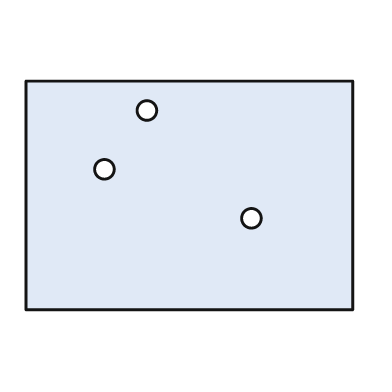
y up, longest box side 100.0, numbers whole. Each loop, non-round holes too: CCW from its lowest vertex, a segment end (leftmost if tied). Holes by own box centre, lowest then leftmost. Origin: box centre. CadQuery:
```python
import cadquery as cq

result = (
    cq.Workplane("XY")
    .moveTo(-50.0, -35.0)
    .lineTo(50.0, -35.0)
    .lineTo(50.0, 35.0)
    .lineTo(-50.0, 35.0)
    .close()
    .moveTo(19.0, -7.0)
    .circle(3.0)
    .moveTo(-26.0, 8.0)
    .circle(3.0)
    .moveTo(-13.0, 26.0)
    .circle(3.0)
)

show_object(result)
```